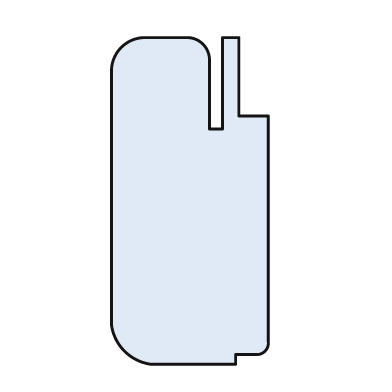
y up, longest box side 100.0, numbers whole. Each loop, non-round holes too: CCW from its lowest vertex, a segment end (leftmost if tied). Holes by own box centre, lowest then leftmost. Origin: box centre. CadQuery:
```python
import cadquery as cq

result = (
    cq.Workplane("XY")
    .moveTo(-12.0, -50.0)
    .lineTo(14.0, -50.0)
    .lineTo(14.0, -47.0)
    .lineTo(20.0, -47.0)
    .threePointArc((23.0, -46.0), (24.0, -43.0))
    .lineTo(24.0, 26.0)
    .lineTo(15.0, 26.0)
    .lineTo(15.0, 50.0)
    .lineTo(10.0, 50.0)
    .lineTo(10.0, 22.0)
    .lineTo(6.0, 22.0)
    .lineTo(6.0, 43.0)
    .threePointArc((4.0, 48.0), (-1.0, 50.0))
    .lineTo(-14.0, 50.0)
    .threePointArc((-21.0, 47.0), (-24.0, 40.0))
    .lineTo(-24.0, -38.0)
    .threePointArc((-20.0, -46.0), (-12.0, -50.0))
    .close()
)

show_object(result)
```